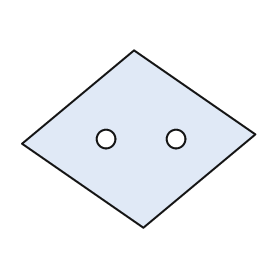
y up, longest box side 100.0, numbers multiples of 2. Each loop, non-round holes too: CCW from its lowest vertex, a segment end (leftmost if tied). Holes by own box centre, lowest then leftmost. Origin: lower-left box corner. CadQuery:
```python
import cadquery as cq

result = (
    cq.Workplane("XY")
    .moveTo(52.0, 0.0)
    .lineTo(100.0, 40.0)
    .lineTo(48.0, 76.0)
    .lineTo(0.0, 36.0)
    .close()
    .moveTo(36.0, 38.0)
    .circle(4.0)
    .moveTo(66.0, 38.0)
    .circle(4.0)
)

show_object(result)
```